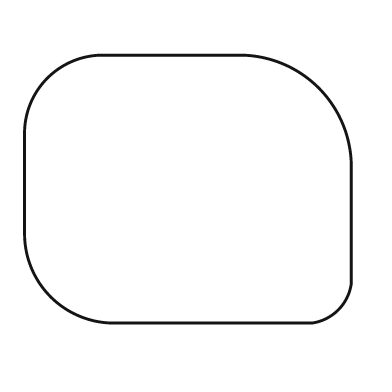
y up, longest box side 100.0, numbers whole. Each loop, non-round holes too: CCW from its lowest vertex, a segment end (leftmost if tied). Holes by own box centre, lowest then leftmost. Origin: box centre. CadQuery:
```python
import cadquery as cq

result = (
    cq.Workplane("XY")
    .moveTo(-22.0, -41.0)
    .lineTo(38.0, -41.0)
    .threePointArc((46.0, -37.0), (50.0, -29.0))
    .lineTo(50.0, 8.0)
    .threePointArc((40.0, 31.0), (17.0, 41.0))
    .lineTo(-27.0, 41.0)
    .threePointArc((-43.0, 34.0), (-50.0, 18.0))
    .lineTo(-50.0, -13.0)
    .threePointArc((-42.0, -33.0), (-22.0, -41.0))
    .close()
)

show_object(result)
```